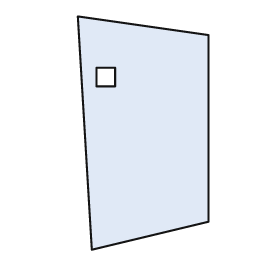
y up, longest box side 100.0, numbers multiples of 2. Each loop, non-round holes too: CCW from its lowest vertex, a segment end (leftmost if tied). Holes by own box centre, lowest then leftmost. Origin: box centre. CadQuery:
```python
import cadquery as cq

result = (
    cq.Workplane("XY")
    .moveTo(-22.0, -50.0)
    .lineTo(28.0, -38.0)
    .lineTo(28.0, 42.0)
    .lineTo(-28.0, 50.0)
    .close()
    .moveTo(-20.0, 20.0)
    .lineTo(-12.0, 20.0)
    .lineTo(-12.0, 28.0)
    .lineTo(-20.0, 28.0)
    .close()
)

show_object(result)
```